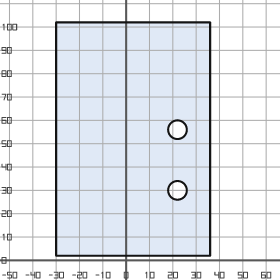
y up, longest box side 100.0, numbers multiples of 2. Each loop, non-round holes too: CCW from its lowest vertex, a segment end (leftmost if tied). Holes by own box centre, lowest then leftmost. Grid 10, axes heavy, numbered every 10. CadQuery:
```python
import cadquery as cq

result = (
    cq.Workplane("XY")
    .moveTo(-30.0, 2.0)
    .lineTo(36.0, 2.0)
    .lineTo(36.0, 102.0)
    .lineTo(-30.0, 102.0)
    .close()
    .moveTo(22.0, 30.0)
    .circle(4.0)
    .moveTo(22.0, 56.0)
    .circle(4.0)
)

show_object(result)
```